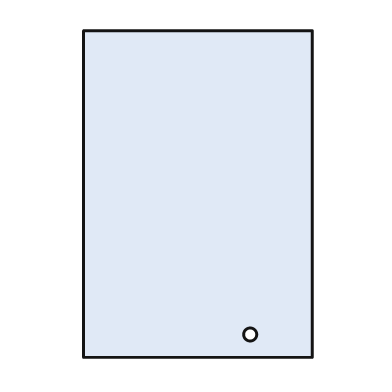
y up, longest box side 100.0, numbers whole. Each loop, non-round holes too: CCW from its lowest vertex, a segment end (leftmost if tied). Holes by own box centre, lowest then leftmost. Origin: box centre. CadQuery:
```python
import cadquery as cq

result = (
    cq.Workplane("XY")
    .moveTo(-35.0, -50.0)
    .lineTo(35.0, -50.0)
    .lineTo(35.0, 50.0)
    .lineTo(-35.0, 50.0)
    .close()
    .moveTo(16.0, -43.0)
    .circle(2.0)
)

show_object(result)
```